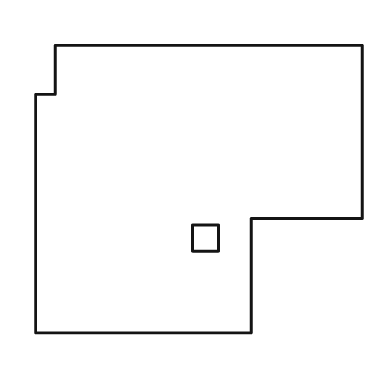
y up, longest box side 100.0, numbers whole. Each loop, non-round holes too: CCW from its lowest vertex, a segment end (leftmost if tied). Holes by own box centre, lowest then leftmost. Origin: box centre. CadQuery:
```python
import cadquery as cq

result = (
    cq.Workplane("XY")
    .moveTo(-50.0, -44.0)
    .lineTo(16.0, -44.0)
    .lineTo(16.0, -9.0)
    .lineTo(50.0, -9.0)
    .lineTo(50.0, 44.0)
    .lineTo(-44.0, 44.0)
    .lineTo(-44.0, 29.0)
    .lineTo(-50.0, 29.0)
    .close()
    .moveTo(-2.0, -19.0)
    .lineTo(6.0, -19.0)
    .lineTo(6.0, -11.0)
    .lineTo(-2.0, -11.0)
    .close()
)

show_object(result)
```